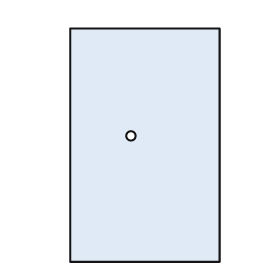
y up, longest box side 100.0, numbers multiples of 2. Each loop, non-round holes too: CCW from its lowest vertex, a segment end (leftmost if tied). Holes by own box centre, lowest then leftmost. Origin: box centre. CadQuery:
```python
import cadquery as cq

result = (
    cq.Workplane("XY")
    .moveTo(-32.0, -50.0)
    .lineTo(32.0, -50.0)
    .lineTo(32.0, 50.0)
    .lineTo(-32.0, 50.0)
    .close()
    .moveTo(-6.0, 4.0)
    .circle(2.0)
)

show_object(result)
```